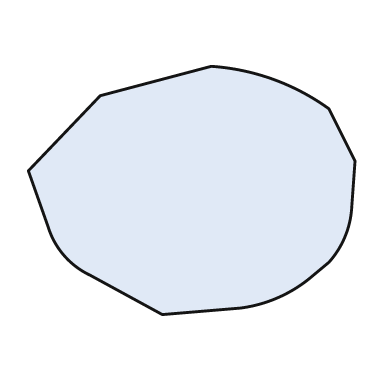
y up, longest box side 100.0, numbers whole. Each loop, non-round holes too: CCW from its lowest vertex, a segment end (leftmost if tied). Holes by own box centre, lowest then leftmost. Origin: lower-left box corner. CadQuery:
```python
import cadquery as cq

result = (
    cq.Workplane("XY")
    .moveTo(41.0, 0.0)
    .lineTo(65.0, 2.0)
    .threePointArc((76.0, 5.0), (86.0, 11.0))
    .lineTo(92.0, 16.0)
    .threePointArc((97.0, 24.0), (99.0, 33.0))
    .lineTo(100.0, 47.0)
    .lineTo(92.0, 63.0)
    .threePointArc((75.0, 72.0), (56.0, 76.0))
    .lineTo(22.0, 67.0)
    .lineTo(0.0, 44.0)
    .lineTo(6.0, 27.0)
    .threePointArc((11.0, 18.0), (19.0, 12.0))
    .close()
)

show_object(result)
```